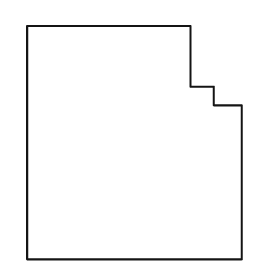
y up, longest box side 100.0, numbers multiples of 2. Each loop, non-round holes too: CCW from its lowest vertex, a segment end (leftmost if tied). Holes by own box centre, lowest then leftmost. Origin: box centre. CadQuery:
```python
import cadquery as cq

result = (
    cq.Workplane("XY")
    .moveTo(-46.0, -50.0)
    .lineTo(46.0, -50.0)
    .lineTo(46.0, 16.0)
    .lineTo(34.0, 16.0)
    .lineTo(34.0, 24.0)
    .lineTo(24.0, 24.0)
    .lineTo(24.0, 50.0)
    .lineTo(-46.0, 50.0)
    .close()
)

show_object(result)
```